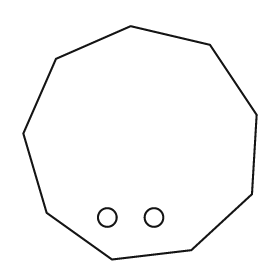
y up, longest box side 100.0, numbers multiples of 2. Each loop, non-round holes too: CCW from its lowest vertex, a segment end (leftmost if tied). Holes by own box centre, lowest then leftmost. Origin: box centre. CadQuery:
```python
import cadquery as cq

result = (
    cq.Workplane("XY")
    .moveTo(-12.0, -50.0)
    .lineTo(22.0, -46.0)
    .lineTo(48.0, -22.0)
    .lineTo(50.0, 12.0)
    .lineTo(30.0, 42.0)
    .lineTo(-4.0, 50.0)
    .lineTo(-36.0, 36.0)
    .lineTo(-50.0, 4.0)
    .lineTo(-40.0, -30.0)
    .close()
    .moveTo(-14.0, -32.0)
    .circle(4.0)
    .moveTo(6.0, -32.0)
    .circle(4.0)
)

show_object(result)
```